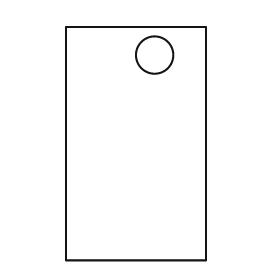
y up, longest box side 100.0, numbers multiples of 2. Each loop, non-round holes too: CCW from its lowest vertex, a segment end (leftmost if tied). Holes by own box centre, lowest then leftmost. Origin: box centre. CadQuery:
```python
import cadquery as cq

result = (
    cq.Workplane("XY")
    .moveTo(-30.0, -50.0)
    .lineTo(30.0, -50.0)
    .lineTo(30.0, 50.0)
    .lineTo(-30.0, 50.0)
    .close()
    .moveTo(8.0, 38.0)
    .circle(8.0)
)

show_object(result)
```